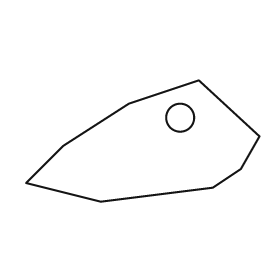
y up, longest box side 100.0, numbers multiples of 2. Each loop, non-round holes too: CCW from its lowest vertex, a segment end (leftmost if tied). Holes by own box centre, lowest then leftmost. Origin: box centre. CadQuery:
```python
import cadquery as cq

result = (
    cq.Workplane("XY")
    .moveTo(-18.0, -26.0)
    .lineTo(30.0, -20.0)
    .lineTo(42.0, -12.0)
    .lineTo(50.0, 2.0)
    .lineTo(24.0, 26.0)
    .lineTo(-6.0, 16.0)
    .lineTo(-34.0, -2.0)
    .lineTo(-50.0, -18.0)
    .close()
    .moveTo(16.0, 10.0)
    .circle(6.0)
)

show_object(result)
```